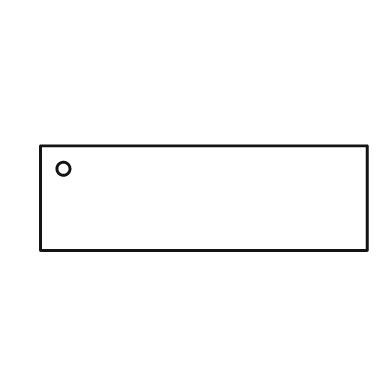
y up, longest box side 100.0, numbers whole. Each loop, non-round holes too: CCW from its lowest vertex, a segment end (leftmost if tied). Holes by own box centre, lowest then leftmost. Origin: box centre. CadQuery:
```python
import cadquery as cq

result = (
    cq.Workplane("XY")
    .moveTo(-50.0, -16.0)
    .lineTo(50.0, -16.0)
    .lineTo(50.0, 16.0)
    .lineTo(-50.0, 16.0)
    .close()
    .moveTo(-43.0, 9.0)
    .circle(2.0)
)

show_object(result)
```